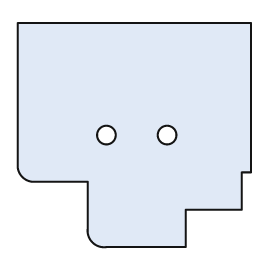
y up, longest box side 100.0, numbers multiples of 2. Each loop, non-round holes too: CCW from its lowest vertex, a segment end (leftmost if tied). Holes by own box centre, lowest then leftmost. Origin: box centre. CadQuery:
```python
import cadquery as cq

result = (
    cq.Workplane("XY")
    .moveTo(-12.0, -48.0)
    .lineTo(22.0, -48.0)
    .lineTo(22.0, -32.0)
    .lineTo(46.0, -32.0)
    .lineTo(46.0, -16.0)
    .lineTo(50.0, -16.0)
    .lineTo(50.0, 48.0)
    .lineTo(-50.0, 48.0)
    .lineTo(-50.0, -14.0)
    .threePointArc((-48.0, -18.0), (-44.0, -20.0))
    .lineTo(-20.0, -20.0)
    .lineTo(-20.0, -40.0)
    .threePointArc((-18.0, -46.0), (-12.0, -48.0))
    .close()
    .moveTo(-12.0, 0.0)
    .circle(4.0)
    .moveTo(14.0, 0.0)
    .circle(4.0)
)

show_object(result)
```